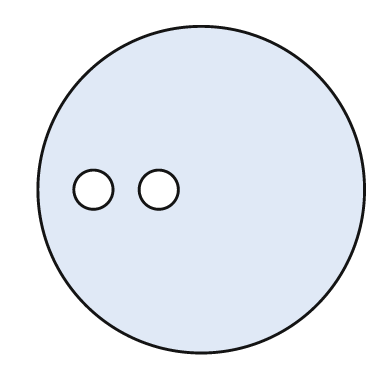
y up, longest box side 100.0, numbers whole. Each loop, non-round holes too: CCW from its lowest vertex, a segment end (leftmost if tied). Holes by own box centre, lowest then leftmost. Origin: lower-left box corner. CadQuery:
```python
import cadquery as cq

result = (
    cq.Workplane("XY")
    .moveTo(50.0, 50.0)
    .circle(50.0)
    .moveTo(17.0, 50.0)
    .circle(6.0)
    .moveTo(37.0, 50.0)
    .circle(6.0)
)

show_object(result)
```